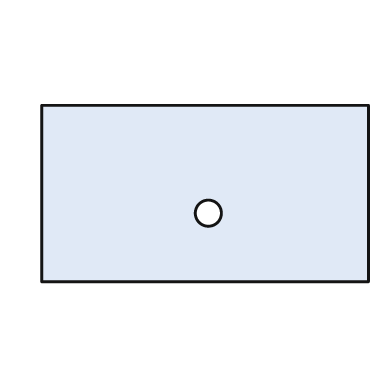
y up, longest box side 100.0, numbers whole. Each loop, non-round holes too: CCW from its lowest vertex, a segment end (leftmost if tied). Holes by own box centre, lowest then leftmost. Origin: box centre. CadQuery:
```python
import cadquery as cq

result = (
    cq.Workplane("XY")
    .moveTo(-50.0, -27.0)
    .lineTo(50.0, -27.0)
    .lineTo(50.0, 27.0)
    .lineTo(-50.0, 27.0)
    .close()
    .moveTo(1.0, -6.0)
    .circle(4.0)
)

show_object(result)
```